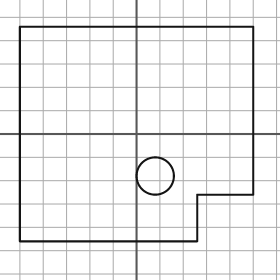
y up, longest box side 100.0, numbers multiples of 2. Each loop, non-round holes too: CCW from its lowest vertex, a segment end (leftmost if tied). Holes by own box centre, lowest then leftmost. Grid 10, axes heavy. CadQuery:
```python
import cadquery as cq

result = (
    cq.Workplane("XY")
    .moveTo(-50.0, -46.0)
    .lineTo(26.0, -46.0)
    .lineTo(26.0, -26.0)
    .lineTo(50.0, -26.0)
    .lineTo(50.0, 46.0)
    .lineTo(-50.0, 46.0)
    .close()
    .moveTo(8.0, -18.0)
    .circle(8.0)
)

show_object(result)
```